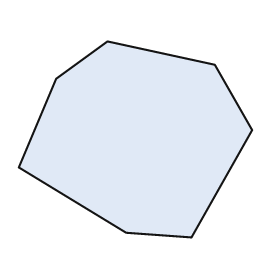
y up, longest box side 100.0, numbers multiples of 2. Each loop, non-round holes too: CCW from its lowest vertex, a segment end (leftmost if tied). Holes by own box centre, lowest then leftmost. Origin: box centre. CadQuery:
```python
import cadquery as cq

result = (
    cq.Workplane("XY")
    .moveTo(24.0, -42.0)
    .lineTo(50.0, 4.0)
    .lineTo(34.0, 32.0)
    .lineTo(-12.0, 42.0)
    .lineTo(-34.0, 26.0)
    .lineTo(-50.0, -12.0)
    .lineTo(-4.0, -40.0)
    .close()
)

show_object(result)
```